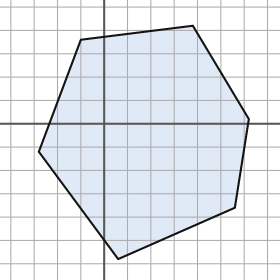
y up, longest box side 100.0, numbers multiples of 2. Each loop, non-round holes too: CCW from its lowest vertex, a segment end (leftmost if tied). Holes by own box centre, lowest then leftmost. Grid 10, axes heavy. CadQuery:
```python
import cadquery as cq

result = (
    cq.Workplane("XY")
    .moveTo(6.0, -58.0)
    .lineTo(56.0, -36.0)
    .lineTo(62.0, 2.0)
    .lineTo(38.0, 42.0)
    .lineTo(-10.0, 36.0)
    .lineTo(-28.0, -12.0)
    .close()
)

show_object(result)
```